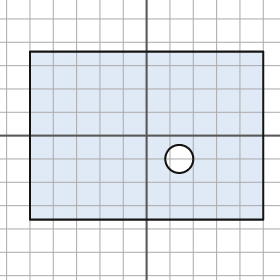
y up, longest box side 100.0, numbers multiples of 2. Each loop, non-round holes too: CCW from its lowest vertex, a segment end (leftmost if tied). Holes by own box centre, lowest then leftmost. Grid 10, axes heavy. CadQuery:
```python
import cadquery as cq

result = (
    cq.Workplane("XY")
    .moveTo(-50.0, -36.0)
    .lineTo(50.0, -36.0)
    .lineTo(50.0, 36.0)
    .lineTo(-50.0, 36.0)
    .close()
    .moveTo(14.0, -10.0)
    .circle(6.0)
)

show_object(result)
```